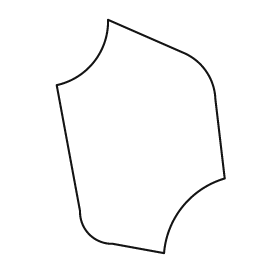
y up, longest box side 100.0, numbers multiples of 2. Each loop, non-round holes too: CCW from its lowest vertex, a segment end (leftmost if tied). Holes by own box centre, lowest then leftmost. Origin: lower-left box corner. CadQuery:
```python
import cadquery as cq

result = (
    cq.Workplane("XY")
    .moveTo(46.0, 0.0)
    .threePointArc((54.0, 20.0), (72.0, 32.0))
    .lineTo(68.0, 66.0)
    .threePointArc((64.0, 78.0), (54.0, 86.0))
    .lineTo(22.0, 100.0)
    .threePointArc((16.0, 82.0), (0.0, 72.0))
    .lineTo(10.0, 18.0)
    .threePointArc((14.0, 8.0), (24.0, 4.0))
    .close()
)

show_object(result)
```